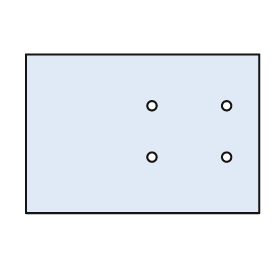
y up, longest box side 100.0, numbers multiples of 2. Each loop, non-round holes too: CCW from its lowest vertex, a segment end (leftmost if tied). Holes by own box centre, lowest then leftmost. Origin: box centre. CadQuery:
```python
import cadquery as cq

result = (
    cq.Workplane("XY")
    .moveTo(-50.0, -34.0)
    .lineTo(50.0, -34.0)
    .lineTo(50.0, 34.0)
    .lineTo(-50.0, 34.0)
    .close()
    .moveTo(4.0, -10.0)
    .circle(2.0)
    .moveTo(36.0, -10.0)
    .circle(2.0)
    .moveTo(4.0, 12.0)
    .circle(2.0)
    .moveTo(36.0, 12.0)
    .circle(2.0)
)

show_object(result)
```